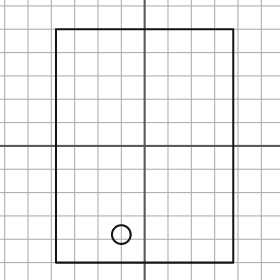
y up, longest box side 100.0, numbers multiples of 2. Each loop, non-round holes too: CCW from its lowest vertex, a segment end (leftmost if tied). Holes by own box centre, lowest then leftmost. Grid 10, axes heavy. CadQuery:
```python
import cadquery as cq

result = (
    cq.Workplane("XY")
    .moveTo(-38.0, -50.0)
    .lineTo(38.0, -50.0)
    .lineTo(38.0, 50.0)
    .lineTo(-38.0, 50.0)
    .close()
    .moveTo(-10.0, -38.0)
    .circle(4.0)
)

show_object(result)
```